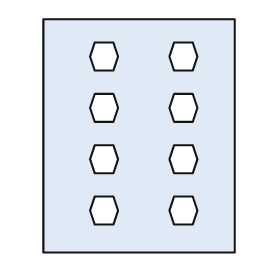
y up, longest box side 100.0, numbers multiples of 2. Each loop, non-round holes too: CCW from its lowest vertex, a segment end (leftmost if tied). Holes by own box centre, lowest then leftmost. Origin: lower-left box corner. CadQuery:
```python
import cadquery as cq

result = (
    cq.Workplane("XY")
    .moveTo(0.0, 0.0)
    .lineTo(82.0, 0.0)
    .lineTo(82.0, 100.0)
    .lineTo(0.0, 100.0)
    .close()
    .moveTo(22.0, 12.0)
    .lineTo(30.0, 12.0)
    .lineTo(32.0, 18.0)
    .lineTo(30.0, 24.0)
    .lineTo(22.0, 24.0)
    .lineTo(20.0, 18.0)
    .close()
    .moveTo(56.0, 12.0)
    .lineTo(64.0, 12.0)
    .lineTo(66.0, 18.0)
    .lineTo(64.0, 24.0)
    .lineTo(56.0, 24.0)
    .lineTo(54.0, 18.0)
    .close()
    .moveTo(22.0, 34.0)
    .lineTo(30.0, 34.0)
    .lineTo(32.0, 40.0)
    .lineTo(30.0, 46.0)
    .lineTo(22.0, 46.0)
    .lineTo(20.0, 40.0)
    .close()
    .moveTo(56.0, 34.0)
    .lineTo(64.0, 34.0)
    .lineTo(66.0, 40.0)
    .lineTo(64.0, 46.0)
    .lineTo(56.0, 46.0)
    .lineTo(54.0, 40.0)
    .close()
    .moveTo(22.0, 56.0)
    .lineTo(30.0, 56.0)
    .lineTo(32.0, 62.0)
    .lineTo(30.0, 68.0)
    .lineTo(22.0, 68.0)
    .lineTo(20.0, 62.0)
    .close()
    .moveTo(56.0, 56.0)
    .lineTo(64.0, 56.0)
    .lineTo(66.0, 62.0)
    .lineTo(64.0, 68.0)
    .lineTo(56.0, 68.0)
    .lineTo(54.0, 62.0)
    .close()
    .moveTo(22.0, 78.0)
    .lineTo(30.0, 78.0)
    .lineTo(32.0, 84.0)
    .lineTo(30.0, 90.0)
    .lineTo(22.0, 90.0)
    .lineTo(20.0, 84.0)
    .close()
    .moveTo(56.0, 78.0)
    .lineTo(64.0, 78.0)
    .lineTo(66.0, 84.0)
    .lineTo(64.0, 90.0)
    .lineTo(56.0, 90.0)
    .lineTo(54.0, 84.0)
    .close()
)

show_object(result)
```